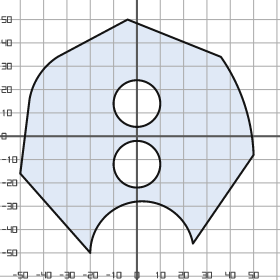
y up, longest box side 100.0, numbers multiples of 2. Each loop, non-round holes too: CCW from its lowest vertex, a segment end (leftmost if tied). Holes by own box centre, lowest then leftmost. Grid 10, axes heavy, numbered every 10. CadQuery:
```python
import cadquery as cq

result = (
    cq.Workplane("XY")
    .moveTo(-20.0, -50.0)
    .threePointArc((0.0, -28.0), (24.0, -46.0))
    .lineTo(50.0, -8.0)
    .threePointArc((46.0, 14.0), (36.0, 34.0))
    .lineTo(-4.0, 50.0)
    .lineTo(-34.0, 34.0)
    .threePointArc((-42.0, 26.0), (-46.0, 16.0))
    .lineTo(-50.0, -16.0)
    .close()
    .moveTo(0.0, -12.0)
    .circle(10.0)
    .moveTo(0.0, 14.0)
    .circle(10.0)
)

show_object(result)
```